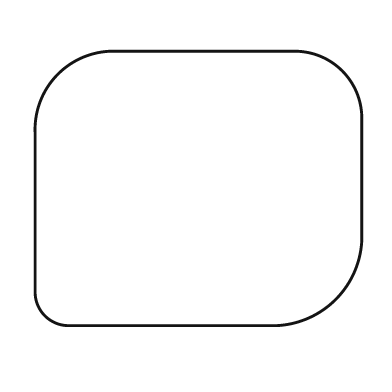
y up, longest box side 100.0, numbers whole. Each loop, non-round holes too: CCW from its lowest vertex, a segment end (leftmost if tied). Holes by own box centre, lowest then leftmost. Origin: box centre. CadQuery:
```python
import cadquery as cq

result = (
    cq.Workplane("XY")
    .moveTo(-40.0, -42.0)
    .lineTo(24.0, -42.0)
    .threePointArc((42.0, -34.0), (50.0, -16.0))
    .lineTo(50.0, 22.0)
    .threePointArc((44.0, 36.0), (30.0, 42.0))
    .lineTo(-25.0, 42.0)
    .threePointArc((-43.0, 35.0), (-50.0, 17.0))
    .lineTo(-50.0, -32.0)
    .threePointArc((-47.0, -39.0), (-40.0, -42.0))
    .close()
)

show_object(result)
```